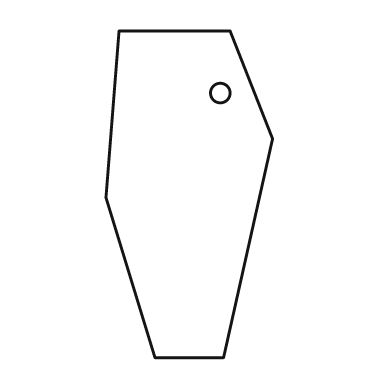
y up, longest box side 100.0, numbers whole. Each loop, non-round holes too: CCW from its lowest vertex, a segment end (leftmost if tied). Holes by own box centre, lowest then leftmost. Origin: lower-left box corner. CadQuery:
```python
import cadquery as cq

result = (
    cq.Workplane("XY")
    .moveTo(15.0, 0.0)
    .lineTo(36.0, 0.0)
    .lineTo(51.0, 67.0)
    .lineTo(38.0, 100.0)
    .lineTo(4.0, 100.0)
    .lineTo(0.0, 49.0)
    .close()
    .moveTo(35.0, 81.0)
    .circle(3.0)
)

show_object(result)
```